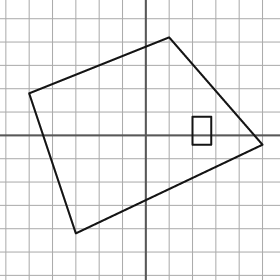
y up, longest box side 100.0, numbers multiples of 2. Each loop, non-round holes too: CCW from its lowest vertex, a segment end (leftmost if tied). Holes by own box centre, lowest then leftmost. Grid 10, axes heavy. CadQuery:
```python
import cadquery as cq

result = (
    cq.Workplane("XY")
    .moveTo(-30.0, -42.0)
    .lineTo(50.0, -4.0)
    .lineTo(10.0, 42.0)
    .lineTo(-50.0, 18.0)
    .close()
    .moveTo(20.0, -4.0)
    .lineTo(28.0, -4.0)
    .lineTo(28.0, 8.0)
    .lineTo(20.0, 8.0)
    .close()
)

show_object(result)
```